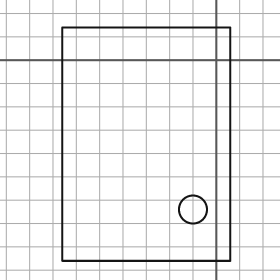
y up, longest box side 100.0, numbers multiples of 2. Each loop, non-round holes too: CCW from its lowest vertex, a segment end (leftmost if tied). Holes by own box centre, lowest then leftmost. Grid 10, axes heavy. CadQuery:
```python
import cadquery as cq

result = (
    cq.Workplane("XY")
    .moveTo(-66.0, -86.0)
    .lineTo(6.0, -86.0)
    .lineTo(6.0, 14.0)
    .lineTo(-66.0, 14.0)
    .close()
    .moveTo(-10.0, -64.0)
    .circle(6.0)
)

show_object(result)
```